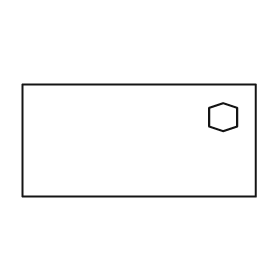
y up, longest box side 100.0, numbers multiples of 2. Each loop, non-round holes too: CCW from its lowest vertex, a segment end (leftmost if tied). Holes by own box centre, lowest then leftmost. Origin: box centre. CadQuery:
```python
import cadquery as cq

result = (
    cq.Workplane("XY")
    .moveTo(-50.0, -24.0)
    .lineTo(50.0, -24.0)
    .lineTo(50.0, 24.0)
    .lineTo(-50.0, 24.0)
    .close()
    .moveTo(36.0, 4.0)
    .lineTo(42.0, 6.0)
    .lineTo(42.0, 14.0)
    .lineTo(36.0, 16.0)
    .lineTo(30.0, 14.0)
    .lineTo(30.0, 6.0)
    .close()
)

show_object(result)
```